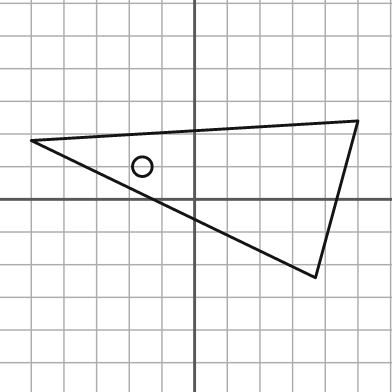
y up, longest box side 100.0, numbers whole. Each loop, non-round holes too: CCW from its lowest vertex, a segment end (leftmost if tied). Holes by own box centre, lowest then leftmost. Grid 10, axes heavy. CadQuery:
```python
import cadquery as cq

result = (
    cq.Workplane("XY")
    .moveTo(37.0, -24.0)
    .lineTo(50.0, 24.0)
    .lineTo(-50.0, 18.0)
    .close()
    .moveTo(-16.0, 10.0)
    .circle(3.0)
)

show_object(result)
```